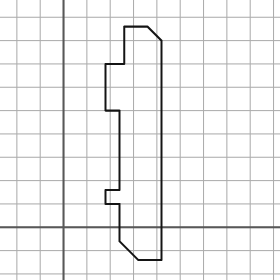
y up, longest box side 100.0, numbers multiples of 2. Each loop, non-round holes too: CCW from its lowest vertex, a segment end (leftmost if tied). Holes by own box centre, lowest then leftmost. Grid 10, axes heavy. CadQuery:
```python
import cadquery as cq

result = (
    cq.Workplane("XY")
    .moveTo(32.0, -14.0)
    .lineTo(42.0, -14.0)
    .lineTo(42.0, 80.0)
    .lineTo(36.0, 86.0)
    .lineTo(26.0, 86.0)
    .lineTo(26.0, 70.0)
    .lineTo(18.0, 70.0)
    .lineTo(18.0, 50.0)
    .lineTo(24.0, 50.0)
    .lineTo(24.0, 16.0)
    .lineTo(18.0, 16.0)
    .lineTo(18.0, 10.0)
    .lineTo(24.0, 10.0)
    .lineTo(24.0, -6.0)
    .close()
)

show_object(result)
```